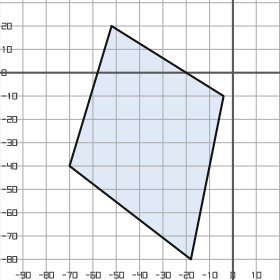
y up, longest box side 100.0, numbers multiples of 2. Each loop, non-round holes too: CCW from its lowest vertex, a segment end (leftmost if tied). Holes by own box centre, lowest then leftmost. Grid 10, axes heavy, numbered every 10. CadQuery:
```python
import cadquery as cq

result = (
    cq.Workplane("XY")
    .moveTo(-18.0, -80.0)
    .lineTo(-4.0, -10.0)
    .lineTo(-52.0, 20.0)
    .lineTo(-70.0, -40.0)
    .close()
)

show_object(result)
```